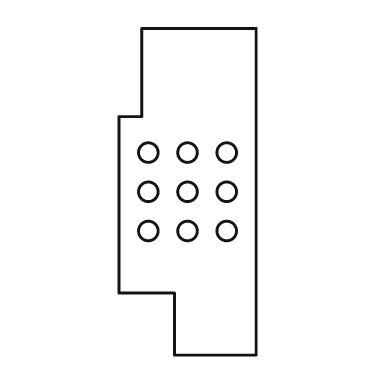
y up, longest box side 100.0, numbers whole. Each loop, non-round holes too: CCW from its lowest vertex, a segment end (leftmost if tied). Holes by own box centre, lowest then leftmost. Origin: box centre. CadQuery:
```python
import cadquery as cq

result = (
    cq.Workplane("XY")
    .moveTo(-4.0, -50.0)
    .lineTo(21.0, -50.0)
    .lineTo(21.0, 50.0)
    .lineTo(-14.0, 50.0)
    .lineTo(-14.0, 23.0)
    .lineTo(-21.0, 23.0)
    .lineTo(-21.0, -31.0)
    .lineTo(-4.0, -31.0)
    .close()
    .moveTo(-12.0, -12.0)
    .circle(3.0)
    .moveTo(0.0, -12.0)
    .circle(3.0)
    .moveTo(12.0, -12.0)
    .circle(3.0)
    .moveTo(-12.0, 0.0)
    .circle(3.0)
    .moveTo(0.0, 0.0)
    .circle(3.0)
    .moveTo(12.0, 0.0)
    .circle(3.0)
    .moveTo(-12.0, 12.0)
    .circle(3.0)
    .moveTo(0.0, 12.0)
    .circle(3.0)
    .moveTo(12.0, 12.0)
    .circle(3.0)
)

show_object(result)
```